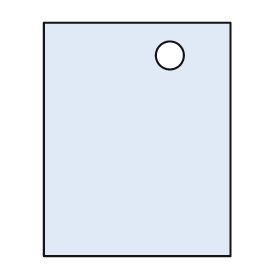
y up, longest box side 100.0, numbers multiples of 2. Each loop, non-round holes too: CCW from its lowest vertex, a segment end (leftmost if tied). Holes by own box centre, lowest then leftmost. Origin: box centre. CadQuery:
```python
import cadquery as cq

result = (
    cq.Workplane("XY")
    .moveTo(-40.0, -50.0)
    .lineTo(40.0, -50.0)
    .lineTo(40.0, 50.0)
    .lineTo(-40.0, 50.0)
    .close()
    .moveTo(14.0, 36.0)
    .circle(6.0)
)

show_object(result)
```